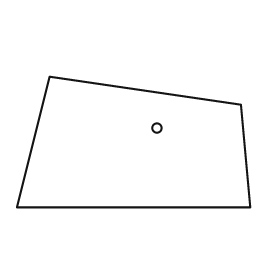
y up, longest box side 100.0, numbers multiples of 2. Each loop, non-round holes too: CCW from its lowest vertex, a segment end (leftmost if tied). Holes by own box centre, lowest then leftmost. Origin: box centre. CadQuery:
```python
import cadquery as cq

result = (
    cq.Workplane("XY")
    .moveTo(-50.0, -28.0)
    .lineTo(50.0, -28.0)
    .lineTo(46.0, 16.0)
    .lineTo(-36.0, 28.0)
    .close()
    .moveTo(10.0, 6.0)
    .circle(2.0)
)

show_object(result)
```